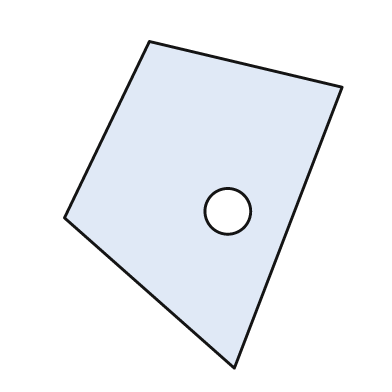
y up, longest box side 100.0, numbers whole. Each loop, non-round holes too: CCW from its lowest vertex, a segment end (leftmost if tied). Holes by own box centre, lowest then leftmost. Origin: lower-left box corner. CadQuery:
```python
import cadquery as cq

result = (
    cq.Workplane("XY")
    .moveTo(52.0, 0.0)
    .lineTo(85.0, 86.0)
    .lineTo(26.0, 100.0)
    .lineTo(0.0, 46.0)
    .close()
    .moveTo(50.0, 48.0)
    .circle(7.0)
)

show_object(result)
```